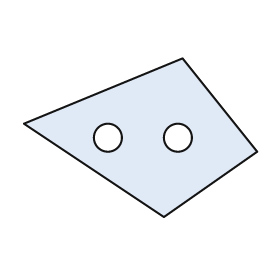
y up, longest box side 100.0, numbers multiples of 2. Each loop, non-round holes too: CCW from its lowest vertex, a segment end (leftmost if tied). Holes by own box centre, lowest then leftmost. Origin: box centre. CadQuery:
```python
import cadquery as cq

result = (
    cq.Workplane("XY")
    .moveTo(10.0, -34.0)
    .lineTo(50.0, -6.0)
    .lineTo(18.0, 34.0)
    .lineTo(-50.0, 6.0)
    .close()
    .moveTo(-14.0, 0.0)
    .circle(6.0)
    .moveTo(16.0, 0.0)
    .circle(6.0)
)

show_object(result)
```